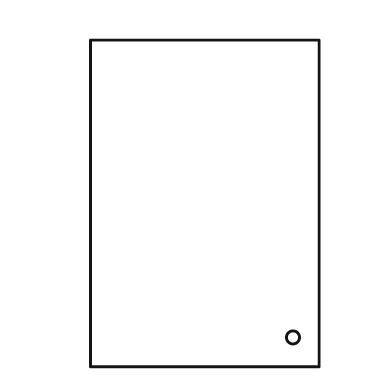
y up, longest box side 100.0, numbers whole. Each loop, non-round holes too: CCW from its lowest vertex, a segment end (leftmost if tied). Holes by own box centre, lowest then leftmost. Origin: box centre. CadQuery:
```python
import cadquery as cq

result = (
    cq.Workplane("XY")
    .moveTo(-35.0, -50.0)
    .lineTo(35.0, -50.0)
    .lineTo(35.0, 50.0)
    .lineTo(-35.0, 50.0)
    .close()
    .moveTo(27.0, -41.0)
    .circle(2.0)
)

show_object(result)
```